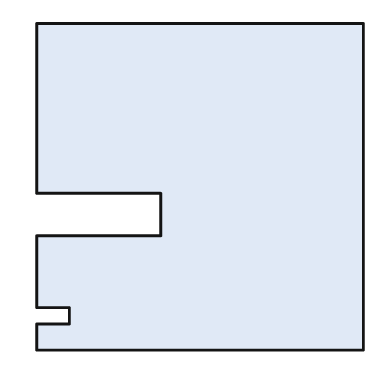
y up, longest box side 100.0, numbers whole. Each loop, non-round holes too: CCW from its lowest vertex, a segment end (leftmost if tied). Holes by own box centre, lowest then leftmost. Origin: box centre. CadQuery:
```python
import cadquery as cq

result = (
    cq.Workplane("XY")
    .moveTo(-50.0, -50.0)
    .lineTo(50.0, -50.0)
    .lineTo(50.0, 50.0)
    .lineTo(-50.0, 50.0)
    .lineTo(-50.0, -2.0)
    .lineTo(-12.0, -2.0)
    .lineTo(-12.0, -15.0)
    .lineTo(-50.0, -15.0)
    .lineTo(-50.0, -37.0)
    .lineTo(-40.0, -37.0)
    .lineTo(-40.0, -42.0)
    .lineTo(-50.0, -42.0)
    .close()
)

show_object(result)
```